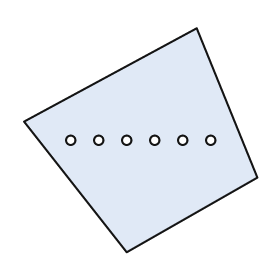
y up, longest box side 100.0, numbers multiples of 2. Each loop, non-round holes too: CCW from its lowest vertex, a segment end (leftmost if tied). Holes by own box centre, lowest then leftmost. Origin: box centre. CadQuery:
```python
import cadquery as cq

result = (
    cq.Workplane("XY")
    .moveTo(-6.0, -48.0)
    .lineTo(50.0, -16.0)
    .lineTo(24.0, 48.0)
    .lineTo(-50.0, 8.0)
    .close()
    .moveTo(-30.0, 0.0)
    .circle(2.0)
    .moveTo(-18.0, 0.0)
    .circle(2.0)
    .moveTo(-6.0, 0.0)
    .circle(2.0)
    .moveTo(6.0, 0.0)
    .circle(2.0)
    .moveTo(18.0, 0.0)
    .circle(2.0)
    .moveTo(30.0, 0.0)
    .circle(2.0)
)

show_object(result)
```